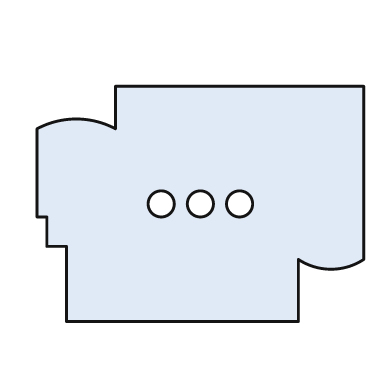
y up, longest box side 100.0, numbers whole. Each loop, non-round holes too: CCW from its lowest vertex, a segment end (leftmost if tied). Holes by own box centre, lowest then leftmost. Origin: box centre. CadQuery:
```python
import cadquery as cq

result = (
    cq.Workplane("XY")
    .moveTo(-41.0, -36.0)
    .lineTo(30.0, -36.0)
    .lineTo(30.0, -17.0)
    .threePointArc((40.0, -20.0), (50.0, -17.0))
    .lineTo(50.0, 36.0)
    .lineTo(-26.0, 36.0)
    .lineTo(-26.0, 23.0)
    .threePointArc((-38.0, 26.0), (-50.0, 23.0))
    .lineTo(-50.0, -4.0)
    .lineTo(-47.0, -4.0)
    .lineTo(-47.0, -13.0)
    .lineTo(-41.0, -13.0)
    .close()
    .moveTo(-12.0, 0.0)
    .circle(4.0)
    .moveTo(0.0, 0.0)
    .circle(4.0)
    .moveTo(12.0, 0.0)
    .circle(4.0)
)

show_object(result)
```